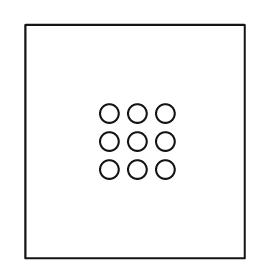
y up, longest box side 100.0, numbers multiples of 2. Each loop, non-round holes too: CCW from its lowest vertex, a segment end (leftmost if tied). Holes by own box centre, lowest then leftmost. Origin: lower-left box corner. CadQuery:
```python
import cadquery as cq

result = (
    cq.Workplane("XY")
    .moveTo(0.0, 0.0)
    .lineTo(94.0, 0.0)
    .lineTo(94.0, 100.0)
    .lineTo(0.0, 100.0)
    .close()
    .moveTo(36.0, 38.0)
    .circle(4.0)
    .moveTo(48.0, 38.0)
    .circle(4.0)
    .moveTo(60.0, 38.0)
    .circle(4.0)
    .moveTo(36.0, 50.0)
    .circle(4.0)
    .moveTo(48.0, 50.0)
    .circle(4.0)
    .moveTo(60.0, 50.0)
    .circle(4.0)
    .moveTo(36.0, 62.0)
    .circle(4.0)
    .moveTo(48.0, 62.0)
    .circle(4.0)
    .moveTo(60.0, 62.0)
    .circle(4.0)
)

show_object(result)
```